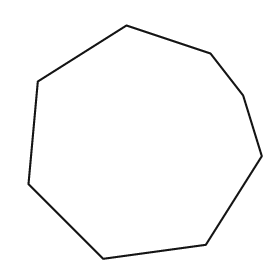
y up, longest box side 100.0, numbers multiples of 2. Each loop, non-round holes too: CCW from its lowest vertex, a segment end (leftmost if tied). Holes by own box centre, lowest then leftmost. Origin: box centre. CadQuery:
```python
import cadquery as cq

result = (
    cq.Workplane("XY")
    .moveTo(-18.0, -50.0)
    .lineTo(26.0, -44.0)
    .lineTo(50.0, -6.0)
    .lineTo(42.0, 20.0)
    .lineTo(28.0, 38.0)
    .lineTo(-8.0, 50.0)
    .lineTo(-46.0, 26.0)
    .lineTo(-50.0, -18.0)
    .close()
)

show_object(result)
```